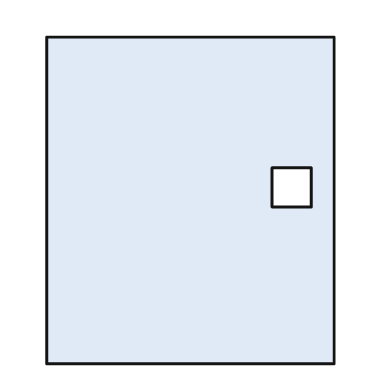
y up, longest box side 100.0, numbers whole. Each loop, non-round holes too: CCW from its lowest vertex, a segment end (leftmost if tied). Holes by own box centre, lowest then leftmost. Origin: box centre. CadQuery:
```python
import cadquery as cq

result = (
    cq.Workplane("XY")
    .moveTo(-44.0, -50.0)
    .lineTo(44.0, -50.0)
    .lineTo(44.0, 50.0)
    .lineTo(-44.0, 50.0)
    .close()
    .moveTo(25.0, -2.0)
    .lineTo(37.0, -2.0)
    .lineTo(37.0, 10.0)
    .lineTo(25.0, 10.0)
    .close()
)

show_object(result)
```